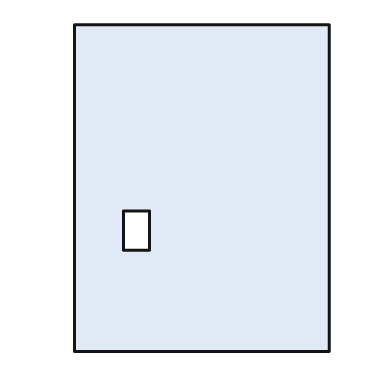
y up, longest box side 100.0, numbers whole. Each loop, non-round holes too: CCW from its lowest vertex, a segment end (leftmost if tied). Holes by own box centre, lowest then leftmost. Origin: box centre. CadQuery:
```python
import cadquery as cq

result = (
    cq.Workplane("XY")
    .moveTo(-39.0, -50.0)
    .lineTo(39.0, -50.0)
    .lineTo(39.0, 50.0)
    .lineTo(-39.0, 50.0)
    .close()
    .moveTo(-24.0, -19.0)
    .lineTo(-16.0, -19.0)
    .lineTo(-16.0, -7.0)
    .lineTo(-24.0, -7.0)
    .close()
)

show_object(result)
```